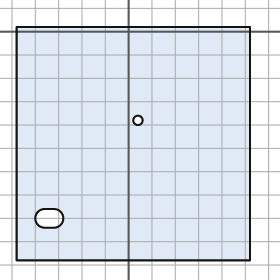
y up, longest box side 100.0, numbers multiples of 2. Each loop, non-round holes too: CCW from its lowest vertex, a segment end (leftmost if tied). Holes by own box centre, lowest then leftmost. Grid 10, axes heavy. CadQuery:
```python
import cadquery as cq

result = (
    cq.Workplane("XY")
    .moveTo(-48.0, -98.0)
    .lineTo(52.0, -98.0)
    .lineTo(52.0, 2.0)
    .lineTo(-48.0, 2.0)
    .close()
    .moveTo(-36.0, -84.0)
    .lineTo(-32.0, -84.0)
    .threePointArc((-28.0, -80.0), (-32.0, -76.0))
    .lineTo(-36.0, -76.0)
    .threePointArc((-40.0, -80.0), (-36.0, -84.0))
    .close()
    .moveTo(4.0, -38.0)
    .circle(2.0)
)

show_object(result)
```